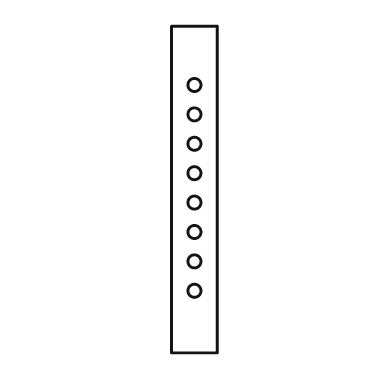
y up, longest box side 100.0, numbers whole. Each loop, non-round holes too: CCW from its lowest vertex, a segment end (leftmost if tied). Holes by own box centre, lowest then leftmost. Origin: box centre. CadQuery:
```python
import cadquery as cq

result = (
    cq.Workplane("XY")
    .moveTo(-7.0, -50.0)
    .lineTo(7.0, -50.0)
    .lineTo(7.0, 50.0)
    .lineTo(-7.0, 50.0)
    .close()
    .moveTo(0.0, -31.0)
    .circle(2.0)
    .moveTo(0.0, -22.0)
    .circle(2.0)
    .moveTo(0.0, -13.0)
    .circle(2.0)
    .moveTo(0.0, -4.0)
    .circle(2.0)
    .moveTo(0.0, 5.0)
    .circle(2.0)
    .moveTo(0.0, 14.0)
    .circle(2.0)
    .moveTo(0.0, 23.0)
    .circle(2.0)
    .moveTo(0.0, 32.0)
    .circle(2.0)
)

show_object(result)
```